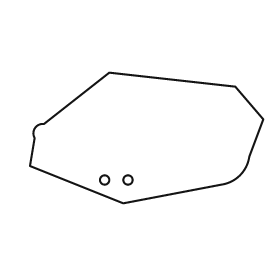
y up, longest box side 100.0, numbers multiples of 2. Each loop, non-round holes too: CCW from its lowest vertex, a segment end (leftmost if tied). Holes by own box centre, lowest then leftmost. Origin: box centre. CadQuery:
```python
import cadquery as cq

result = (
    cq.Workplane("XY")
    .moveTo(-10.0, -28.0)
    .lineTo(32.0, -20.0)
    .threePointArc((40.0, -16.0), (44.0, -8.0))
    .lineTo(50.0, 8.0)
    .lineTo(38.0, 22.0)
    .lineTo(-16.0, 28.0)
    .lineTo(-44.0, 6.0)
    .threePointArc((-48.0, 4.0), (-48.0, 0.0))
    .lineTo(-50.0, -12.0)
    .close()
    .moveTo(-18.0, -18.0)
    .circle(2.0)
    .moveTo(-8.0, -18.0)
    .circle(2.0)
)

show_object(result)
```